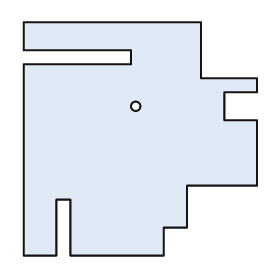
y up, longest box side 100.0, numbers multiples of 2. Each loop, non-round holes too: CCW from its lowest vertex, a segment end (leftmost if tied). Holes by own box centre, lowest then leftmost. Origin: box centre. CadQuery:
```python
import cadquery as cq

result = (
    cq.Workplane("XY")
    .moveTo(-50.0, -50.0)
    .lineTo(-36.0, -50.0)
    .lineTo(-36.0, -26.0)
    .lineTo(-30.0, -26.0)
    .lineTo(-30.0, -50.0)
    .lineTo(10.0, -50.0)
    .lineTo(10.0, -38.0)
    .lineTo(20.0, -38.0)
    .lineTo(20.0, -20.0)
    .lineTo(50.0, -20.0)
    .lineTo(50.0, 8.0)
    .lineTo(36.0, 8.0)
    .lineTo(36.0, 20.0)
    .lineTo(50.0, 20.0)
    .lineTo(50.0, 26.0)
    .lineTo(26.0, 26.0)
    .lineTo(26.0, 50.0)
    .lineTo(-50.0, 50.0)
    .lineTo(-50.0, 38.0)
    .lineTo(-4.0, 38.0)
    .lineTo(-4.0, 32.0)
    .lineTo(-50.0, 32.0)
    .close()
    .moveTo(-2.0, 14.0)
    .circle(2.0)
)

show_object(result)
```